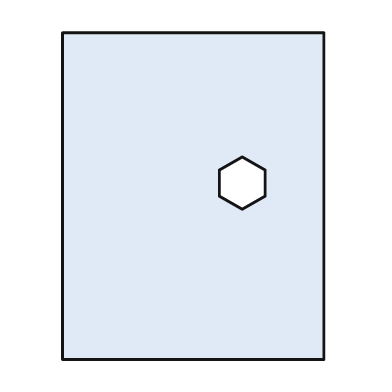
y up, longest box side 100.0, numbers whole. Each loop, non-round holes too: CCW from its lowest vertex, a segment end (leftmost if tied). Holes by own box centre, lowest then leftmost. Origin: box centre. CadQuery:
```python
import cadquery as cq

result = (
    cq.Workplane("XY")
    .moveTo(-40.0, -50.0)
    .lineTo(40.0, -50.0)
    .lineTo(40.0, 50.0)
    .lineTo(-40.0, 50.0)
    .close()
    .moveTo(15.0, -4.0)
    .lineTo(22.0, 0.0)
    .lineTo(22.0, 8.0)
    .lineTo(15.0, 12.0)
    .lineTo(8.0, 8.0)
    .lineTo(8.0, 0.0)
    .close()
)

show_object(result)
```